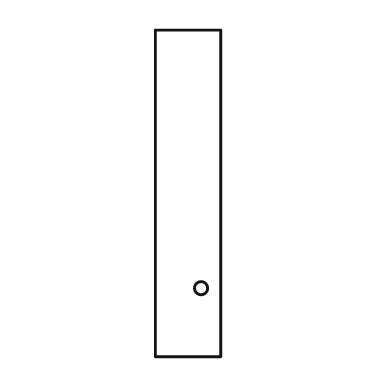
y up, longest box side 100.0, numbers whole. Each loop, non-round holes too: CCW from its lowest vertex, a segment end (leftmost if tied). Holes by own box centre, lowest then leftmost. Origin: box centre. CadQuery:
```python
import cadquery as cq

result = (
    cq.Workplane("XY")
    .moveTo(-10.0, -50.0)
    .lineTo(10.0, -50.0)
    .lineTo(10.0, 50.0)
    .lineTo(-10.0, 50.0)
    .close()
    .moveTo(4.0, -29.0)
    .circle(2.0)
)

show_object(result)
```